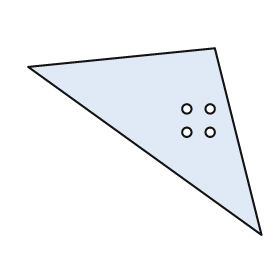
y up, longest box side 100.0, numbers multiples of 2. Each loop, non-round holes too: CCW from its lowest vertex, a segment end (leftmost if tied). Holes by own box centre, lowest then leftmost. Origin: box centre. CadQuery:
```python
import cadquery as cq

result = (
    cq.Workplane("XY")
    .moveTo(50.0, -40.0)
    .lineTo(30.0, 40.0)
    .lineTo(-50.0, 32.0)
    .close()
    .moveTo(18.0, 4.0)
    .circle(2.0)
    .moveTo(28.0, 4.0)
    .circle(2.0)
    .moveTo(18.0, 14.0)
    .circle(2.0)
    .moveTo(28.0, 14.0)
    .circle(2.0)
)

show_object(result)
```